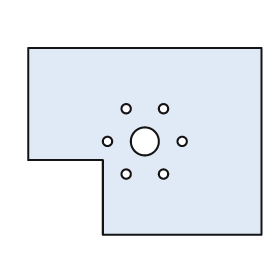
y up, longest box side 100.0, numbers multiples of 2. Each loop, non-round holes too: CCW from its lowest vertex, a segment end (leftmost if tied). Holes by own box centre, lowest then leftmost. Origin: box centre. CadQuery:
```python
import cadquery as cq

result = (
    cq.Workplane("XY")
    .moveTo(-18.0, -40.0)
    .lineTo(50.0, -40.0)
    .lineTo(50.0, 40.0)
    .lineTo(-50.0, 40.0)
    .lineTo(-50.0, -8.0)
    .lineTo(-18.0, -8.0)
    .close()
    .moveTo(-8.0, -14.0)
    .circle(2.0)
    .moveTo(8.0, -14.0)
    .circle(2.0)
    .moveTo(-16.0, 0.0)
    .circle(2.0)
    .moveTo(0.0, 0.0)
    .circle(6.0)
    .moveTo(16.0, 0.0)
    .circle(2.0)
    .moveTo(-8.0, 14.0)
    .circle(2.0)
    .moveTo(8.0, 14.0)
    .circle(2.0)
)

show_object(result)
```